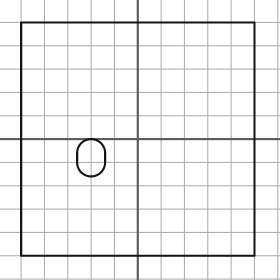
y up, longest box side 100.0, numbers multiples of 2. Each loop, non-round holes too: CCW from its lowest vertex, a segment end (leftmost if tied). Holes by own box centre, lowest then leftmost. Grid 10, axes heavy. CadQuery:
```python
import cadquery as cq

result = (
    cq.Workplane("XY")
    .moveTo(-50.0, -50.0)
    .lineTo(50.0, -50.0)
    .lineTo(50.0, 50.0)
    .lineTo(-50.0, 50.0)
    .close()
    .moveTo(-26.0, -10.0)
    .threePointArc((-20.0, -16.0), (-14.0, -10.0))
    .lineTo(-14.0, -6.0)
    .threePointArc((-20.0, 0.0), (-26.0, -6.0))
    .close()
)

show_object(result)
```